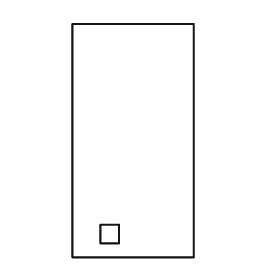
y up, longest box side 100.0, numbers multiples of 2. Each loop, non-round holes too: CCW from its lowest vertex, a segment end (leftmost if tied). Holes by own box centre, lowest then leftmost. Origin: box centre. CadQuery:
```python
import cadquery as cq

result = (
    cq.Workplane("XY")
    .moveTo(-26.0, -50.0)
    .lineTo(26.0, -50.0)
    .lineTo(26.0, 50.0)
    .lineTo(-26.0, 50.0)
    .close()
    .moveTo(-14.0, -44.0)
    .lineTo(-6.0, -44.0)
    .lineTo(-6.0, -36.0)
    .lineTo(-14.0, -36.0)
    .close()
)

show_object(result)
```